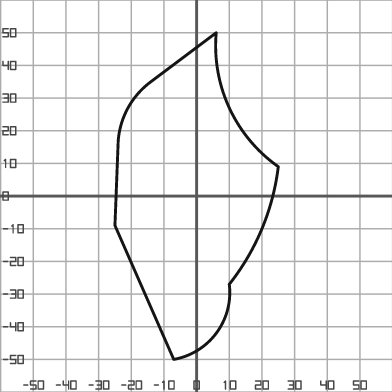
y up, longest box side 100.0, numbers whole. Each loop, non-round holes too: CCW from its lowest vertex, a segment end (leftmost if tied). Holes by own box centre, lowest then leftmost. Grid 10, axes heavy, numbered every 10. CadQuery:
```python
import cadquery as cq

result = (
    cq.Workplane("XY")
    .moveTo(-7.0, -50.0)
    .threePointArc((6.0, -42.0), (10.0, -27.0))
    .threePointArc((20.0, -10.0), (25.0, 9.0))
    .threePointArc((10.0, 27.0), (6.0, 50.0))
    .lineTo(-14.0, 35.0)
    .threePointArc((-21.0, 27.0), (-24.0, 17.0))
    .lineTo(-25.0, -9.0)
    .close()
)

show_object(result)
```